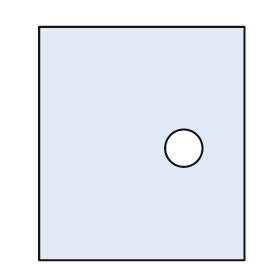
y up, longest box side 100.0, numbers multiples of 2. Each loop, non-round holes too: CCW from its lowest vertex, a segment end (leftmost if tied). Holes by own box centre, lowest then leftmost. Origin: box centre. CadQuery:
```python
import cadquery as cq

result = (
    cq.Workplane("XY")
    .moveTo(-44.0, -50.0)
    .lineTo(44.0, -50.0)
    .lineTo(44.0, 50.0)
    .lineTo(-44.0, 50.0)
    .close()
    .moveTo(18.0, -2.0)
    .circle(8.0)
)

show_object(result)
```